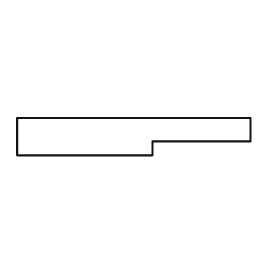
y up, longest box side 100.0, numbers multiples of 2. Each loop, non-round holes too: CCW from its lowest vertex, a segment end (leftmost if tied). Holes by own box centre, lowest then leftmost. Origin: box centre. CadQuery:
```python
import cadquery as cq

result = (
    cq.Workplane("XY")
    .moveTo(-50.0, -8.0)
    .lineTo(8.0, -8.0)
    .lineTo(8.0, -2.0)
    .lineTo(50.0, -2.0)
    .lineTo(50.0, 8.0)
    .lineTo(-50.0, 8.0)
    .close()
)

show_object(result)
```